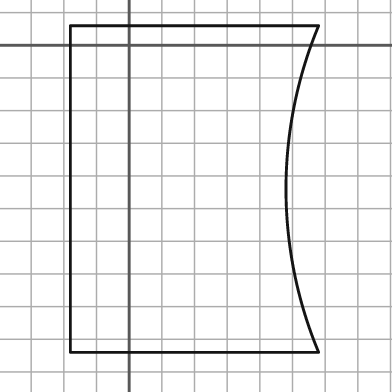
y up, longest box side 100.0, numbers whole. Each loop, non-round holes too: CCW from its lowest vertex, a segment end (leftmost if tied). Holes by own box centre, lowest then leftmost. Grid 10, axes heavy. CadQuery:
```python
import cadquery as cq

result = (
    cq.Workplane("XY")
    .moveTo(-18.0, -94.0)
    .lineTo(58.0, -94.0)
    .threePointArc((48.0, -44.0), (58.0, 6.0))
    .lineTo(-18.0, 6.0)
    .close()
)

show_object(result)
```